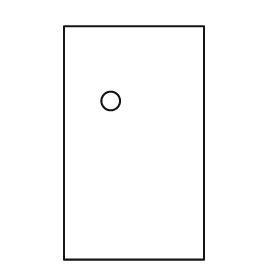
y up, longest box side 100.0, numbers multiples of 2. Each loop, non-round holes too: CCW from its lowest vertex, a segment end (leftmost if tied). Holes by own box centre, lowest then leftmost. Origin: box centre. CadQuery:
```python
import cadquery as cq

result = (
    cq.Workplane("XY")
    .moveTo(-30.0, -50.0)
    .lineTo(30.0, -50.0)
    .lineTo(30.0, 50.0)
    .lineTo(-30.0, 50.0)
    .close()
    .moveTo(-10.0, 18.0)
    .circle(4.0)
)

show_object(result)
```